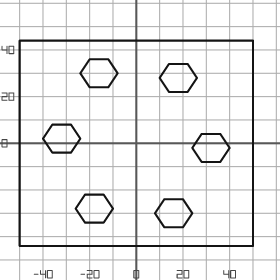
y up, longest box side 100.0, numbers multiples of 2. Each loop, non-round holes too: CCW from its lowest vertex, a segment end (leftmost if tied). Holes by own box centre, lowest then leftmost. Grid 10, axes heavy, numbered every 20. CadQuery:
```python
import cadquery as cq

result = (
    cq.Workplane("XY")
    .moveTo(-50.0, -44.0)
    .lineTo(50.0, -44.0)
    .lineTo(50.0, 44.0)
    .lineTo(-50.0, 44.0)
    .close()
    .moveTo(12.0, -36.0)
    .lineTo(20.0, -36.0)
    .lineTo(24.0, -30.0)
    .lineTo(20.0, -24.0)
    .lineTo(12.0, -24.0)
    .lineTo(8.0, -30.0)
    .close()
    .moveTo(-22.0, -34.0)
    .lineTo(-14.0, -34.0)
    .lineTo(-10.0, -28.0)
    .lineTo(-14.0, -22.0)
    .lineTo(-22.0, -22.0)
    .lineTo(-26.0, -28.0)
    .close()
    .moveTo(28.0, -8.0)
    .lineTo(36.0, -8.0)
    .lineTo(40.0, -2.0)
    .lineTo(36.0, 4.0)
    .lineTo(28.0, 4.0)
    .lineTo(24.0, -2.0)
    .close()
    .moveTo(-36.0, -4.0)
    .lineTo(-28.0, -4.0)
    .lineTo(-24.0, 2.0)
    .lineTo(-28.0, 8.0)
    .lineTo(-36.0, 8.0)
    .lineTo(-40.0, 2.0)
    .close()
    .moveTo(14.0, 22.0)
    .lineTo(22.0, 22.0)
    .lineTo(26.0, 28.0)
    .lineTo(22.0, 34.0)
    .lineTo(14.0, 34.0)
    .lineTo(10.0, 28.0)
    .close()
    .moveTo(-20.0, 24.0)
    .lineTo(-12.0, 24.0)
    .lineTo(-8.0, 30.0)
    .lineTo(-12.0, 36.0)
    .lineTo(-20.0, 36.0)
    .lineTo(-24.0, 30.0)
    .close()
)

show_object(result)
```